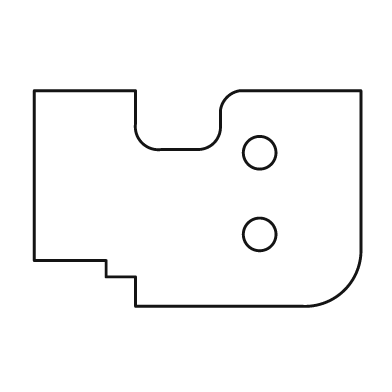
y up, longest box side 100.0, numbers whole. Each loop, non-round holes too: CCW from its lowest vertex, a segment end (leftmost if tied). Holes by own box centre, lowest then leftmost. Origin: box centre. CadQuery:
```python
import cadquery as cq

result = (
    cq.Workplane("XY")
    .moveTo(-19.0, -33.0)
    .lineTo(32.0, -33.0)
    .threePointArc((45.0, -28.0), (50.0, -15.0))
    .lineTo(50.0, 33.0)
    .lineTo(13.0, 33.0)
    .threePointArc((9.0, 31.0), (7.0, 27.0))
    .lineTo(7.0, 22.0)
    .threePointArc((5.0, 17.0), (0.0, 15.0))
    .lineTo(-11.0, 15.0)
    .threePointArc((-17.0, 17.0), (-19.0, 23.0))
    .lineTo(-19.0, 33.0)
    .lineTo(-50.0, 33.0)
    .lineTo(-50.0, -19.0)
    .lineTo(-28.0, -19.0)
    .lineTo(-28.0, -24.0)
    .lineTo(-19.0, -24.0)
    .close()
    .moveTo(19.0, -11.0)
    .circle(5.0)
    .moveTo(19.0, 14.0)
    .circle(5.0)
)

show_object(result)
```